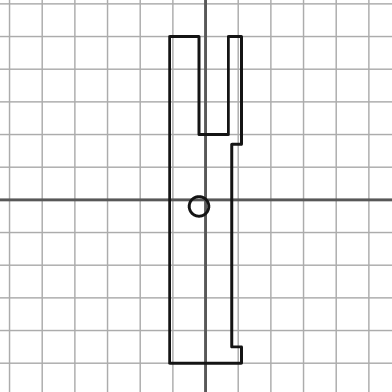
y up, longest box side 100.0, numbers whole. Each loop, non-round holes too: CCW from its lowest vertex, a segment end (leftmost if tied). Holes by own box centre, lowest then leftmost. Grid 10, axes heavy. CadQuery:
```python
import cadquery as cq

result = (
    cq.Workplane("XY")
    .moveTo(-11.0, -50.0)
    .lineTo(11.0, -50.0)
    .lineTo(11.0, -45.0)
    .lineTo(8.0, -45.0)
    .lineTo(8.0, 17.0)
    .lineTo(11.0, 17.0)
    .lineTo(11.0, 50.0)
    .lineTo(7.0, 50.0)
    .lineTo(7.0, 20.0)
    .lineTo(-2.0, 20.0)
    .lineTo(-2.0, 50.0)
    .lineTo(-11.0, 50.0)
    .close()
    .moveTo(-2.0, -2.0)
    .circle(3.0)
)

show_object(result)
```